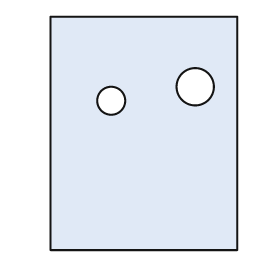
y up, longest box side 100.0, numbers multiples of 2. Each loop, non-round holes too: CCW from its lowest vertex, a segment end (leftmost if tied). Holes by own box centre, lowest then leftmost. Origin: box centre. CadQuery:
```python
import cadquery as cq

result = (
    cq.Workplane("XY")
    .moveTo(-40.0, -50.0)
    .lineTo(40.0, -50.0)
    .lineTo(40.0, 50.0)
    .lineTo(-40.0, 50.0)
    .close()
    .moveTo(-14.0, 14.0)
    .circle(6.0)
    .moveTo(22.0, 20.0)
    .circle(8.0)
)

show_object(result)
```